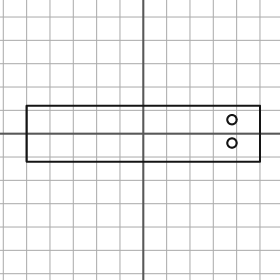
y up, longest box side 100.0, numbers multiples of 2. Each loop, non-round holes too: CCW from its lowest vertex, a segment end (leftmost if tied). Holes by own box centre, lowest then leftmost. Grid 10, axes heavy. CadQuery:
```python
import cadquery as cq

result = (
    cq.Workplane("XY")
    .moveTo(-50.0, -12.0)
    .lineTo(50.0, -12.0)
    .lineTo(50.0, 12.0)
    .lineTo(-50.0, 12.0)
    .close()
    .moveTo(38.0, -4.0)
    .circle(2.0)
    .moveTo(38.0, 6.0)
    .circle(2.0)
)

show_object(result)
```